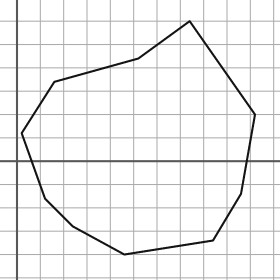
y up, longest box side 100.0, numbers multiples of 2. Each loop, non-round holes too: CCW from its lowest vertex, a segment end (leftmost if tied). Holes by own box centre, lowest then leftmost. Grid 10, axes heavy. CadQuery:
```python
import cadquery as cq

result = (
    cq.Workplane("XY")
    .moveTo(46.0, -40.0)
    .lineTo(84.0, -34.0)
    .lineTo(96.0, -14.0)
    .lineTo(102.0, 20.0)
    .lineTo(74.0, 60.0)
    .lineTo(52.0, 44.0)
    .lineTo(16.0, 34.0)
    .lineTo(2.0, 12.0)
    .lineTo(12.0, -16.0)
    .lineTo(24.0, -28.0)
    .close()
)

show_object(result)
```